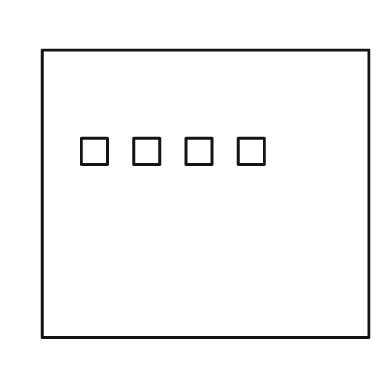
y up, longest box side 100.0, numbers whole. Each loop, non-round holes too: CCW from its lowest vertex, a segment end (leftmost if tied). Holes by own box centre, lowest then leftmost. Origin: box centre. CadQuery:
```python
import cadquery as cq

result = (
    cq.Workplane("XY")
    .moveTo(-50.0, -44.0)
    .lineTo(50.0, -44.0)
    .lineTo(50.0, 44.0)
    .lineTo(-50.0, 44.0)
    .close()
    .moveTo(-38.0, 9.0)
    .lineTo(-30.0, 9.0)
    .lineTo(-30.0, 17.0)
    .lineTo(-38.0, 17.0)
    .close()
    .moveTo(-22.0, 9.0)
    .lineTo(-14.0, 9.0)
    .lineTo(-14.0, 17.0)
    .lineTo(-22.0, 17.0)
    .close()
    .moveTo(-6.0, 9.0)
    .lineTo(2.0, 9.0)
    .lineTo(2.0, 17.0)
    .lineTo(-6.0, 17.0)
    .close()
    .moveTo(10.0, 9.0)
    .lineTo(18.0, 9.0)
    .lineTo(18.0, 17.0)
    .lineTo(10.0, 17.0)
    .close()
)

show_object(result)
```